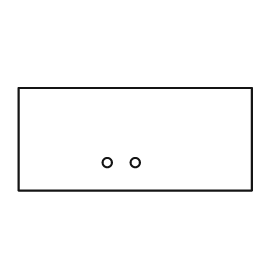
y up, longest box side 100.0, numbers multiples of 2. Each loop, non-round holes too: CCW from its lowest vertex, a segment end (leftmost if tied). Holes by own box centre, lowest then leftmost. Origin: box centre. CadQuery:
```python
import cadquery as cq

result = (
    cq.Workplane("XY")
    .moveTo(-50.0, -22.0)
    .lineTo(50.0, -22.0)
    .lineTo(50.0, 22.0)
    .lineTo(-50.0, 22.0)
    .close()
    .moveTo(-12.0, -10.0)
    .circle(2.0)
    .moveTo(0.0, -10.0)
    .circle(2.0)
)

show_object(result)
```